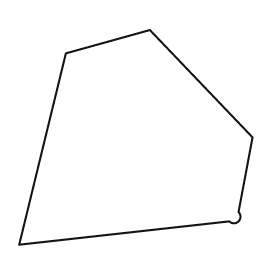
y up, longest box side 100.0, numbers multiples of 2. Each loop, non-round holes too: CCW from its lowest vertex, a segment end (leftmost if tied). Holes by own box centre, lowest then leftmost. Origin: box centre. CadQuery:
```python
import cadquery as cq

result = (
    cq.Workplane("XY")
    .moveTo(-50.0, -46.0)
    .lineTo(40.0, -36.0)
    .threePointArc((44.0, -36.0), (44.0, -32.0))
    .lineTo(50.0, 0.0)
    .lineTo(6.0, 46.0)
    .lineTo(-30.0, 36.0)
    .close()
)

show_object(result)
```